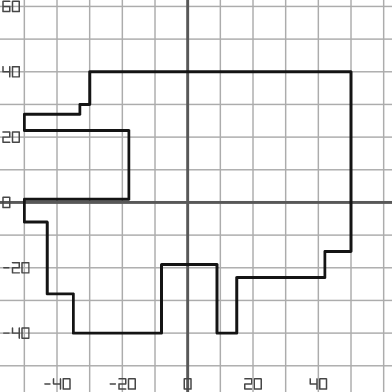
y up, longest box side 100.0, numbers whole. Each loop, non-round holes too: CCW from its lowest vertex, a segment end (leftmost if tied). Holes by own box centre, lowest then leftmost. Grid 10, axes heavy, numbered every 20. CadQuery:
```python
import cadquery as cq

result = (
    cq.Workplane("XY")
    .moveTo(-35.0, -40.0)
    .lineTo(-8.0, -40.0)
    .lineTo(-8.0, -19.0)
    .lineTo(9.0, -19.0)
    .lineTo(9.0, -40.0)
    .lineTo(15.0, -40.0)
    .lineTo(15.0, -23.0)
    .lineTo(42.0, -23.0)
    .lineTo(42.0, -15.0)
    .lineTo(50.0, -15.0)
    .lineTo(50.0, 40.0)
    .lineTo(-30.0, 40.0)
    .lineTo(-30.0, 30.0)
    .lineTo(-33.0, 30.0)
    .lineTo(-33.0, 27.0)
    .lineTo(-50.0, 27.0)
    .lineTo(-50.0, 22.0)
    .lineTo(-18.0, 22.0)
    .lineTo(-18.0, 1.0)
    .lineTo(-50.0, 1.0)
    .lineTo(-50.0, -6.0)
    .lineTo(-43.0, -6.0)
    .lineTo(-43.0, -28.0)
    .lineTo(-35.0, -28.0)
    .close()
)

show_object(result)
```